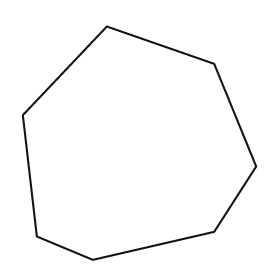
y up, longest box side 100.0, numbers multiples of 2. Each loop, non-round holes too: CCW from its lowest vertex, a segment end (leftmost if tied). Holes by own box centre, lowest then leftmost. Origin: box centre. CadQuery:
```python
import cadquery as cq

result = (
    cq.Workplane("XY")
    .moveTo(-20.0, -50.0)
    .lineTo(32.0, -38.0)
    .lineTo(50.0, -10.0)
    .lineTo(32.0, 34.0)
    .lineTo(-14.0, 50.0)
    .lineTo(-50.0, 12.0)
    .lineTo(-44.0, -40.0)
    .close()
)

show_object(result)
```